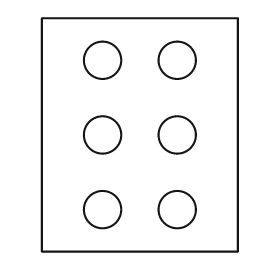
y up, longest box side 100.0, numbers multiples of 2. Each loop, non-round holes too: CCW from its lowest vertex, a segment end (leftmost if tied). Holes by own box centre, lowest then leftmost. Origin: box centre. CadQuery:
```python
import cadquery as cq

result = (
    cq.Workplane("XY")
    .moveTo(-42.0, -50.0)
    .lineTo(42.0, -50.0)
    .lineTo(42.0, 50.0)
    .lineTo(-42.0, 50.0)
    .close()
    .moveTo(-16.0, -32.0)
    .circle(8.0)
    .moveTo(16.0, -32.0)
    .circle(8.0)
    .moveTo(-16.0, 0.0)
    .circle(8.0)
    .moveTo(16.0, 0.0)
    .circle(8.0)
    .moveTo(-16.0, 32.0)
    .circle(8.0)
    .moveTo(16.0, 32.0)
    .circle(8.0)
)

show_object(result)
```